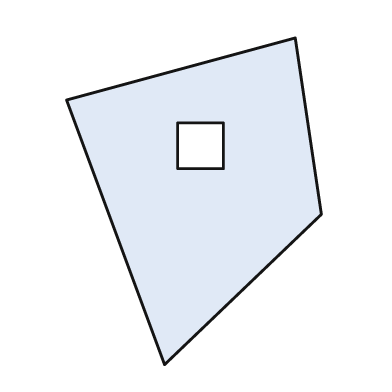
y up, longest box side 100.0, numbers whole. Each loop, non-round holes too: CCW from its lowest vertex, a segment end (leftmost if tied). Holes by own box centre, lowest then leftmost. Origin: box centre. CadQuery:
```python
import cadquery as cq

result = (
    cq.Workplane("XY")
    .moveTo(-9.0, -50.0)
    .lineTo(39.0, -4.0)
    .lineTo(31.0, 50.0)
    .lineTo(-39.0, 31.0)
    .close()
    .moveTo(-5.0, 10.0)
    .lineTo(9.0, 10.0)
    .lineTo(9.0, 24.0)
    .lineTo(-5.0, 24.0)
    .close()
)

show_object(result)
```